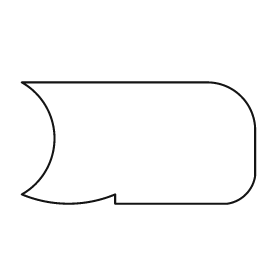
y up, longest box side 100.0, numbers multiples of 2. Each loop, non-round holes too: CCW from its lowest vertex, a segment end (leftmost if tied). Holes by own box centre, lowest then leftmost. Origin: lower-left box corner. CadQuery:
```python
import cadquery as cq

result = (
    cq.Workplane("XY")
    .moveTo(40.0, 0.0)
    .lineTo(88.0, 0.0)
    .threePointArc((96.0, 4.0), (100.0, 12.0))
    .lineTo(100.0, 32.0)
    .threePointArc((94.0, 46.0), (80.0, 52.0))
    .lineTo(0.0, 52.0)
    .threePointArc((14.0, 28.0), (0.0, 4.0))
    .threePointArc((20.0, 0.0), (40.0, 4.0))
    .close()
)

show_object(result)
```